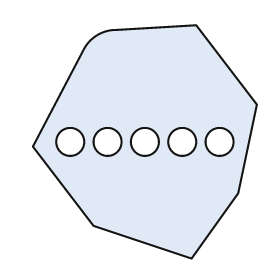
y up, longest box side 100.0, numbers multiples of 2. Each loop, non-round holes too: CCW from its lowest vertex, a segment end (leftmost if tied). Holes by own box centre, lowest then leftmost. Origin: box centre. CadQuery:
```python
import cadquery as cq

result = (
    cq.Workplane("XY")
    .moveTo(20.0, -50.0)
    .lineTo(40.0, -22.0)
    .lineTo(48.0, 16.0)
    .lineTo(22.0, 50.0)
    .lineTo(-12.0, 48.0)
    .threePointArc((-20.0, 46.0), (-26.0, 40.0))
    .lineTo(-48.0, -2.0)
    .lineTo(-22.0, -36.0)
    .close()
    .moveTo(-32.0, 0.0)
    .circle(6.0)
    .moveTo(-16.0, 0.0)
    .circle(6.0)
    .moveTo(0.0, 0.0)
    .circle(6.0)
    .moveTo(16.0, 0.0)
    .circle(6.0)
    .moveTo(32.0, 0.0)
    .circle(6.0)
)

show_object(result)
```